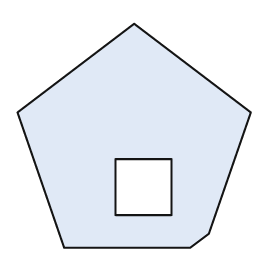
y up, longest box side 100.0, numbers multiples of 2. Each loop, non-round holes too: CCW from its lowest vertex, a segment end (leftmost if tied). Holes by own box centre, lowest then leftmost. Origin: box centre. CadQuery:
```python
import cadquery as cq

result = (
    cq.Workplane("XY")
    .moveTo(-30.0, -48.0)
    .lineTo(24.0, -48.0)
    .lineTo(32.0, -42.0)
    .lineTo(50.0, 10.0)
    .lineTo(0.0, 48.0)
    .lineTo(-50.0, 10.0)
    .close()
    .moveTo(-8.0, -34.0)
    .lineTo(16.0, -34.0)
    .lineTo(16.0, -10.0)
    .lineTo(-8.0, -10.0)
    .close()
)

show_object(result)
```